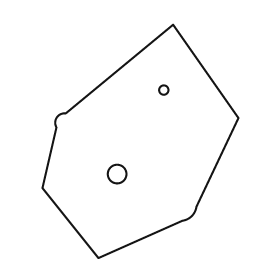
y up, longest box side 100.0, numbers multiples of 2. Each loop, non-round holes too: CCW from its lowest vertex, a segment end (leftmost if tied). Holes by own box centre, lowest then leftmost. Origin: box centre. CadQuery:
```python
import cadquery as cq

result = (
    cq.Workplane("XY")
    .moveTo(-18.0, -50.0)
    .lineTo(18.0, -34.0)
    .threePointArc((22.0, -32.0), (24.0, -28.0))
    .lineTo(42.0, 10.0)
    .lineTo(14.0, 50.0)
    .lineTo(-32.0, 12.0)
    .threePointArc((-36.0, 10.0), (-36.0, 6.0))
    .lineTo(-42.0, -20.0)
    .close()
    .moveTo(-10.0, -14.0)
    .circle(4.0)
    .moveTo(10.0, 22.0)
    .circle(2.0)
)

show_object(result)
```